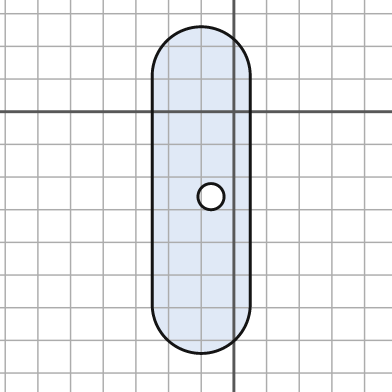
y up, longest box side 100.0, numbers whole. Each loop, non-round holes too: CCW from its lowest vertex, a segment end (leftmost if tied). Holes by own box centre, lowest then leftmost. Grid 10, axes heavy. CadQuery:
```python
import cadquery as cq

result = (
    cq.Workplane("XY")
    .moveTo(-25.0, -59.0)
    .threePointArc((-10.0, -74.0), (5.0, -59.0))
    .lineTo(5.0, 11.0)
    .threePointArc((-10.0, 26.0), (-25.0, 11.0))
    .close()
    .moveTo(-7.0, -26.0)
    .circle(4.0)
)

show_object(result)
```